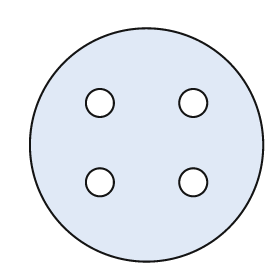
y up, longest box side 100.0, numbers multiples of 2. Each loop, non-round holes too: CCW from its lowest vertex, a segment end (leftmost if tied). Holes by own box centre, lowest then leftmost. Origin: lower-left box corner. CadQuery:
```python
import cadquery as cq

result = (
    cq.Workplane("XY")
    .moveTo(50.0, 50.0)
    .circle(50.0)
    .moveTo(30.0, 34.0)
    .circle(6.0)
    .moveTo(70.0, 34.0)
    .circle(6.0)
    .moveTo(30.0, 68.0)
    .circle(6.0)
    .moveTo(70.0, 68.0)
    .circle(6.0)
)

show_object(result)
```